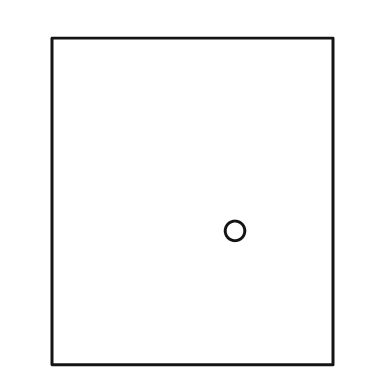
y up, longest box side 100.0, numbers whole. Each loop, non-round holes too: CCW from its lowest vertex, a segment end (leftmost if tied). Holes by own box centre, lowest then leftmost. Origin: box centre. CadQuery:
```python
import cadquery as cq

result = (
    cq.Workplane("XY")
    .moveTo(-43.0, -50.0)
    .lineTo(43.0, -50.0)
    .lineTo(43.0, 50.0)
    .lineTo(-43.0, 50.0)
    .close()
    .moveTo(13.0, -9.0)
    .circle(3.0)
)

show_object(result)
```